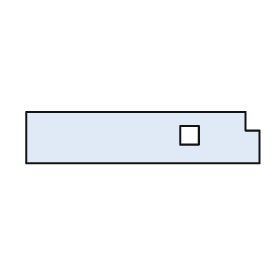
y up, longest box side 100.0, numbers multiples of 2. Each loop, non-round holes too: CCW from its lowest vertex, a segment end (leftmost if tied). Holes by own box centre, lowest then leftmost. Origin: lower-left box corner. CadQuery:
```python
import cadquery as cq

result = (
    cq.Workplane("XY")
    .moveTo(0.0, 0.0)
    .lineTo(100.0, 0.0)
    .lineTo(100.0, 14.0)
    .lineTo(94.0, 14.0)
    .lineTo(94.0, 22.0)
    .lineTo(0.0, 22.0)
    .close()
    .moveTo(66.0, 8.0)
    .lineTo(74.0, 8.0)
    .lineTo(74.0, 16.0)
    .lineTo(66.0, 16.0)
    .close()
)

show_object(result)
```